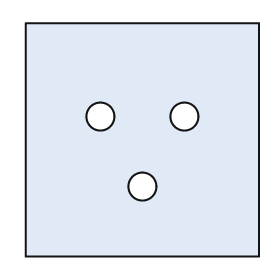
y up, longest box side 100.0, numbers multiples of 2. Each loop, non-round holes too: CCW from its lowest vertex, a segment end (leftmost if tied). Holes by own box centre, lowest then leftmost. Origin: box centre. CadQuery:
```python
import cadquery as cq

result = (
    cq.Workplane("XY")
    .moveTo(-50.0, -50.0)
    .lineTo(50.0, -50.0)
    .lineTo(50.0, 50.0)
    .lineTo(-50.0, 50.0)
    .close()
    .moveTo(0.0, -20.0)
    .circle(6.0)
    .moveTo(-18.0, 10.0)
    .circle(6.0)
    .moveTo(18.0, 10.0)
    .circle(6.0)
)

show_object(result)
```